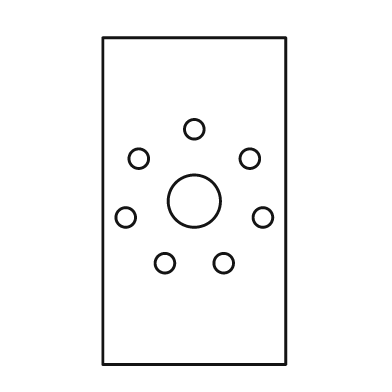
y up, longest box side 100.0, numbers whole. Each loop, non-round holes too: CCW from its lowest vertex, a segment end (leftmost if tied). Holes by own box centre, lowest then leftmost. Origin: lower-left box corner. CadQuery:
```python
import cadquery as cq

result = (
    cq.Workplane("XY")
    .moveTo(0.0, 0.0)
    .lineTo(56.0, 0.0)
    .lineTo(56.0, 100.0)
    .lineTo(0.0, 100.0)
    .close()
    .moveTo(19.0, 31.0)
    .circle(3.0)
    .moveTo(37.0, 31.0)
    .circle(3.0)
    .moveTo(7.0, 45.0)
    .circle(3.0)
    .moveTo(49.0, 45.0)
    .circle(3.0)
    .moveTo(28.0, 50.0)
    .circle(8.0)
    .moveTo(11.0, 63.0)
    .circle(3.0)
    .moveTo(45.0, 63.0)
    .circle(3.0)
    .moveTo(28.0, 72.0)
    .circle(3.0)
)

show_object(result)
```